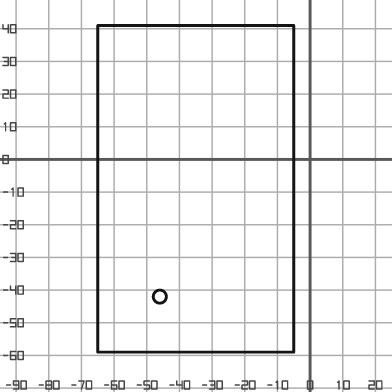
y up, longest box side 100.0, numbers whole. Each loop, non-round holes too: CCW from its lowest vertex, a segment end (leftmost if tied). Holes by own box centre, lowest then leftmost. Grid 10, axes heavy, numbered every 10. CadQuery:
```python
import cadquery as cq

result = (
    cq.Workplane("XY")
    .moveTo(-65.0, -59.0)
    .lineTo(-5.0, -59.0)
    .lineTo(-5.0, 41.0)
    .lineTo(-65.0, 41.0)
    .close()
    .moveTo(-46.0, -42.0)
    .circle(2.0)
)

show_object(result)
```